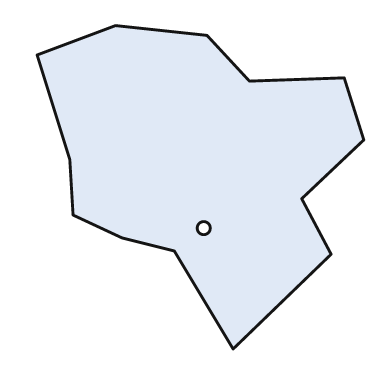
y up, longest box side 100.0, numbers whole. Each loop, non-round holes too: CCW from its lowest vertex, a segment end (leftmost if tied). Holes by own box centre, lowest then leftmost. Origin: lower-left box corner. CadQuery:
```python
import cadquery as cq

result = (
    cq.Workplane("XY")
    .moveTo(60.0, 0.0)
    .lineTo(90.0, 29.0)
    .lineTo(81.0, 46.0)
    .lineTo(100.0, 64.0)
    .lineTo(94.0, 83.0)
    .lineTo(65.0, 82.0)
    .lineTo(52.0, 96.0)
    .lineTo(24.0, 99.0)
    .lineTo(0.0, 90.0)
    .lineTo(10.0, 58.0)
    .lineTo(11.0, 41.0)
    .lineTo(26.0, 34.0)
    .lineTo(42.0, 30.0)
    .close()
    .moveTo(51.0, 37.0)
    .circle(2.0)
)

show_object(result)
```